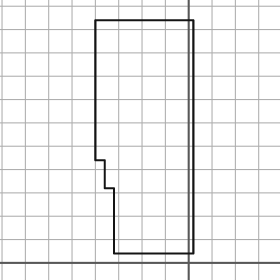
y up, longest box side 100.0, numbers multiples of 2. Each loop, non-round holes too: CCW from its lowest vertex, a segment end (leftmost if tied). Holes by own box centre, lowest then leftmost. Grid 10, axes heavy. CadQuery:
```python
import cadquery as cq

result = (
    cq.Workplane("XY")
    .moveTo(-32.0, 4.0)
    .lineTo(2.0, 4.0)
    .lineTo(2.0, 104.0)
    .lineTo(-40.0, 104.0)
    .lineTo(-40.0, 44.0)
    .lineTo(-36.0, 44.0)
    .lineTo(-36.0, 32.0)
    .lineTo(-32.0, 32.0)
    .close()
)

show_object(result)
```